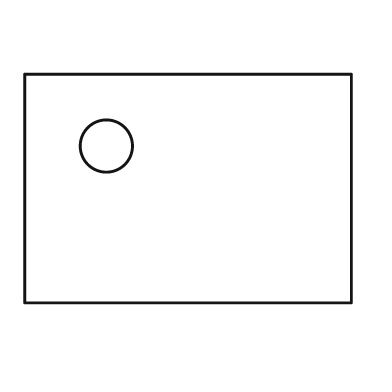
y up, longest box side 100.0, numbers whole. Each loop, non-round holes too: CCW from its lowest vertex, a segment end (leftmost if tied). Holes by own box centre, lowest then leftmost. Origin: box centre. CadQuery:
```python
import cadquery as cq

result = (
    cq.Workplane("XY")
    .moveTo(-50.0, -35.0)
    .lineTo(50.0, -35.0)
    .lineTo(50.0, 35.0)
    .lineTo(-50.0, 35.0)
    .close()
    .moveTo(-25.0, 13.0)
    .circle(8.0)
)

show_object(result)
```